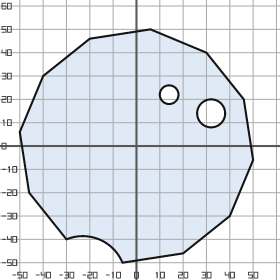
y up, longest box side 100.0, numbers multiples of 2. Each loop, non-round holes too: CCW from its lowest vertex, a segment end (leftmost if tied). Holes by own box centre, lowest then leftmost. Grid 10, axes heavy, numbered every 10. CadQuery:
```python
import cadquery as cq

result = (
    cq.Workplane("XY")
    .moveTo(-6.0, -50.0)
    .lineTo(20.0, -46.0)
    .lineTo(40.0, -30.0)
    .lineTo(50.0, -6.0)
    .lineTo(46.0, 20.0)
    .lineTo(30.0, 40.0)
    .lineTo(6.0, 50.0)
    .lineTo(-20.0, 46.0)
    .lineTo(-40.0, 30.0)
    .lineTo(-50.0, 6.0)
    .lineTo(-46.0, -20.0)
    .lineTo(-30.0, -40.0)
    .threePointArc((-16.0, -40.0), (-6.0, -50.0))
    .close()
    .moveTo(32.0, 14.0)
    .circle(6.0)
    .moveTo(14.0, 22.0)
    .circle(4.0)
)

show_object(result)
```